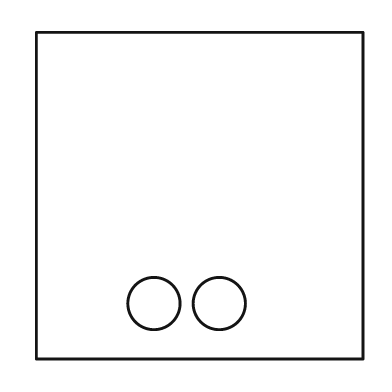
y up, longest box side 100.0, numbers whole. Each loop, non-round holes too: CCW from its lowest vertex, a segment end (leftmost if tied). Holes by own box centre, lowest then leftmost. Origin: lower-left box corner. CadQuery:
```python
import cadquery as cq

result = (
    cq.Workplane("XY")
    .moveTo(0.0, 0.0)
    .lineTo(100.0, 0.0)
    .lineTo(100.0, 100.0)
    .lineTo(0.0, 100.0)
    .close()
    .moveTo(36.0, 17.0)
    .circle(8.0)
    .moveTo(56.0, 17.0)
    .circle(8.0)
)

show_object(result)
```